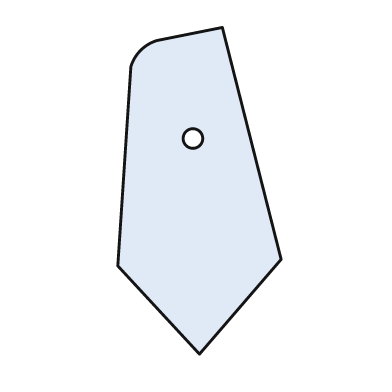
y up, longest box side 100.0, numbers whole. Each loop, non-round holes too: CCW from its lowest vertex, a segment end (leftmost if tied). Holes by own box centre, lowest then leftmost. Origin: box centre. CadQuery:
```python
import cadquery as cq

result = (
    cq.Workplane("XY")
    .moveTo(0.0, -50.0)
    .lineTo(25.0, -21.0)
    .lineTo(7.0, 50.0)
    .lineTo(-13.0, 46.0)
    .threePointArc((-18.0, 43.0), (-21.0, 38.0))
    .lineTo(-25.0, -23.0)
    .close()
    .moveTo(-2.0, 16.0)
    .circle(3.0)
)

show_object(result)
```